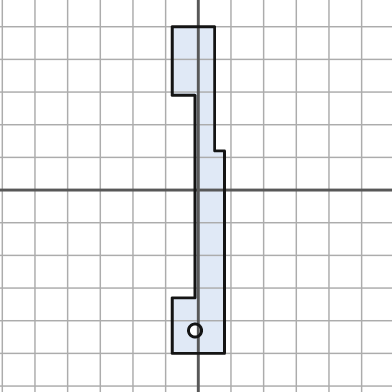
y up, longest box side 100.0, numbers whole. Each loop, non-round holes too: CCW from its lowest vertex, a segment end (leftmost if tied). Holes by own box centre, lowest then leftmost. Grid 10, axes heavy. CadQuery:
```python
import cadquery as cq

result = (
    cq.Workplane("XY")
    .moveTo(-8.0, -50.0)
    .lineTo(8.0, -50.0)
    .lineTo(8.0, 12.0)
    .lineTo(5.0, 12.0)
    .lineTo(5.0, 50.0)
    .lineTo(-8.0, 50.0)
    .lineTo(-8.0, 29.0)
    .lineTo(-1.0, 29.0)
    .lineTo(-1.0, -33.0)
    .lineTo(-8.0, -33.0)
    .close()
    .moveTo(-1.0, -43.0)
    .circle(2.0)
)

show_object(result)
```